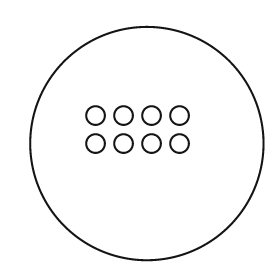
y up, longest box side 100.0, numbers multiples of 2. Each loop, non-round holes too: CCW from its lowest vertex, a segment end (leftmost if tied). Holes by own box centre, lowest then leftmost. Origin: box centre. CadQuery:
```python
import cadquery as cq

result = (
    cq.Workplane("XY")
    .moveTo(0.0, 0.0)
    .circle(50.0)
    .moveTo(-22.0, 0.0)
    .circle(4.0)
    .moveTo(-10.0, 0.0)
    .circle(4.0)
    .moveTo(2.0, 0.0)
    .circle(4.0)
    .moveTo(14.0, 0.0)
    .circle(4.0)
    .moveTo(-22.0, 12.0)
    .circle(4.0)
    .moveTo(-10.0, 12.0)
    .circle(4.0)
    .moveTo(2.0, 12.0)
    .circle(4.0)
    .moveTo(14.0, 12.0)
    .circle(4.0)
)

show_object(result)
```